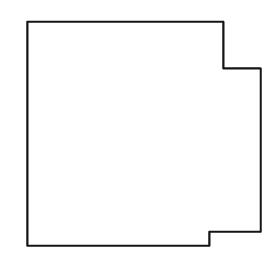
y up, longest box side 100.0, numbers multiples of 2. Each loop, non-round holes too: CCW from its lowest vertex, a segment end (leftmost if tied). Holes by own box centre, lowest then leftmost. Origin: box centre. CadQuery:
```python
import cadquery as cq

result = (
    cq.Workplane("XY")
    .moveTo(-50.0, -48.0)
    .lineTo(28.0, -48.0)
    .lineTo(28.0, -42.0)
    .lineTo(50.0, -42.0)
    .lineTo(50.0, 28.0)
    .lineTo(34.0, 28.0)
    .lineTo(34.0, 48.0)
    .lineTo(-50.0, 48.0)
    .close()
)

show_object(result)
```